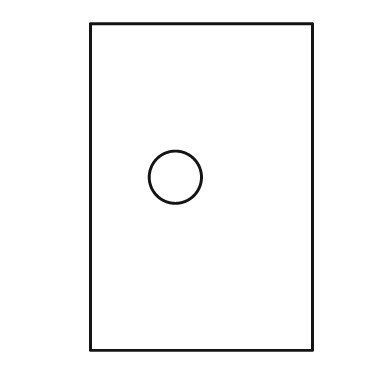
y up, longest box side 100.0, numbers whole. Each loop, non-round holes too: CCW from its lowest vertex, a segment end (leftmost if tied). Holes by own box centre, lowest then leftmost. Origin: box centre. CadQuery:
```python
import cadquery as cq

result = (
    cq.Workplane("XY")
    .moveTo(-34.0, -50.0)
    .lineTo(34.0, -50.0)
    .lineTo(34.0, 50.0)
    .lineTo(-34.0, 50.0)
    .close()
    .moveTo(-8.0, 3.0)
    .circle(8.0)
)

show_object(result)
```